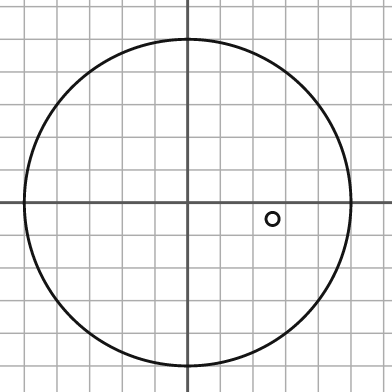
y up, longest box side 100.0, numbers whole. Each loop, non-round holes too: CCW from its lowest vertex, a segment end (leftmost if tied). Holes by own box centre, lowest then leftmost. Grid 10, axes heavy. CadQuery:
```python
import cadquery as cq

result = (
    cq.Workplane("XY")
    .moveTo(0.0, 0.0)
    .circle(50.0)
    .moveTo(26.0, -5.0)
    .circle(2.0)
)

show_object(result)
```